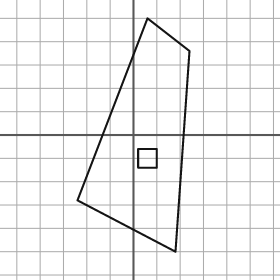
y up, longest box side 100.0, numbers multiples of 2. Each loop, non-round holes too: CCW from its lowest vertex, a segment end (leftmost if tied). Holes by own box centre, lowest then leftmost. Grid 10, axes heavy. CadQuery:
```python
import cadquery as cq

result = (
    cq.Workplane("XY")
    .moveTo(18.0, -50.0)
    .lineTo(24.0, 36.0)
    .lineTo(6.0, 50.0)
    .lineTo(-24.0, -28.0)
    .close()
    .moveTo(2.0, -14.0)
    .lineTo(10.0, -14.0)
    .lineTo(10.0, -6.0)
    .lineTo(2.0, -6.0)
    .close()
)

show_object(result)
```